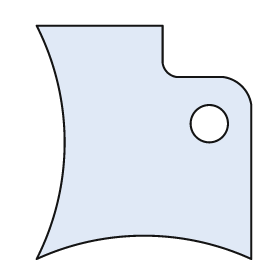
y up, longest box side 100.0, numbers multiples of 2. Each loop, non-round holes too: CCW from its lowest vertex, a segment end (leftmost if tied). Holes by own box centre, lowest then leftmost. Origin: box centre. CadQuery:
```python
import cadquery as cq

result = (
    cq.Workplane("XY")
    .moveTo(-46.0, -50.0)
    .threePointArc((0.0, -40.0), (46.0, -50.0))
    .lineTo(46.0, 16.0)
    .threePointArc((42.0, 24.0), (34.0, 28.0))
    .lineTo(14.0, 28.0)
    .threePointArc((10.0, 30.0), (8.0, 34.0))
    .lineTo(8.0, 50.0)
    .lineTo(-46.0, 50.0)
    .threePointArc((-34.0, 0.0), (-46.0, -50.0))
    .close()
    .moveTo(28.0, 8.0)
    .circle(8.0)
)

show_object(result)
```